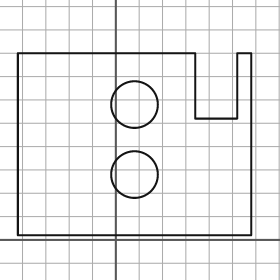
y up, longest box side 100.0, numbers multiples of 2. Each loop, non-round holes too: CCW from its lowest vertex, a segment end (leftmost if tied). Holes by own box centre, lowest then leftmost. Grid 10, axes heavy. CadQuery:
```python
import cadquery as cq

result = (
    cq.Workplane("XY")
    .moveTo(-42.0, 2.0)
    .lineTo(58.0, 2.0)
    .lineTo(58.0, 80.0)
    .lineTo(52.0, 80.0)
    .lineTo(52.0, 52.0)
    .lineTo(34.0, 52.0)
    .lineTo(34.0, 80.0)
    .lineTo(-42.0, 80.0)
    .close()
    .moveTo(8.0, 28.0)
    .circle(10.0)
    .moveTo(8.0, 58.0)
    .circle(10.0)
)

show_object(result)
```